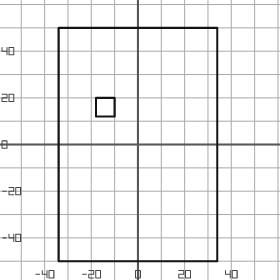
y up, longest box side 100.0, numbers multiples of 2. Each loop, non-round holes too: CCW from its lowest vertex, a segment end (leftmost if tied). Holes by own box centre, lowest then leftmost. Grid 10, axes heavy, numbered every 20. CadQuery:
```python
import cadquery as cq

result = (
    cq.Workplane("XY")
    .moveTo(-34.0, -50.0)
    .lineTo(34.0, -50.0)
    .lineTo(34.0, 50.0)
    .lineTo(-34.0, 50.0)
    .close()
    .moveTo(-18.0, 12.0)
    .lineTo(-10.0, 12.0)
    .lineTo(-10.0, 20.0)
    .lineTo(-18.0, 20.0)
    .close()
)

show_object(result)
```